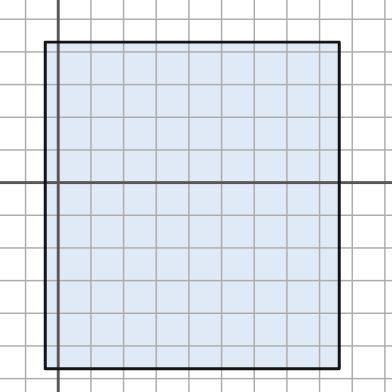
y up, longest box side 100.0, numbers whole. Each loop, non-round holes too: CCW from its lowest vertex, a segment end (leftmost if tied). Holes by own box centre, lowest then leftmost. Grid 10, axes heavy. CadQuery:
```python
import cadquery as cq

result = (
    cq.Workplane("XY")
    .moveTo(-4.0, -57.0)
    .lineTo(86.0, -57.0)
    .lineTo(86.0, 43.0)
    .lineTo(-4.0, 43.0)
    .close()
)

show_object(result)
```